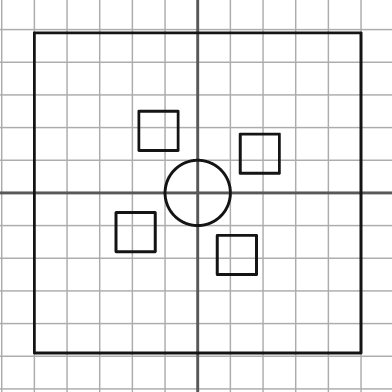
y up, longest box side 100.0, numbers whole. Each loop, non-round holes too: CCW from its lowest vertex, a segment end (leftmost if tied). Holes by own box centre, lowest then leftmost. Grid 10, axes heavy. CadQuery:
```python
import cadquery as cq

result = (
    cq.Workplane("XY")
    .moveTo(-50.0, -49.0)
    .lineTo(50.0, -49.0)
    .lineTo(50.0, 49.0)
    .lineTo(-50.0, 49.0)
    .close()
    .moveTo(6.0, -25.0)
    .lineTo(18.0, -25.0)
    .lineTo(18.0, -13.0)
    .lineTo(6.0, -13.0)
    .close()
    .moveTo(-25.0, -18.0)
    .lineTo(-13.0, -18.0)
    .lineTo(-13.0, -6.0)
    .lineTo(-25.0, -6.0)
    .close()
    .moveTo(0.0, 0.0)
    .circle(10.0)
    .moveTo(13.0, 6.0)
    .lineTo(25.0, 6.0)
    .lineTo(25.0, 18.0)
    .lineTo(13.0, 18.0)
    .close()
    .moveTo(-18.0, 13.0)
    .lineTo(-6.0, 13.0)
    .lineTo(-6.0, 25.0)
    .lineTo(-18.0, 25.0)
    .close()
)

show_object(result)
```